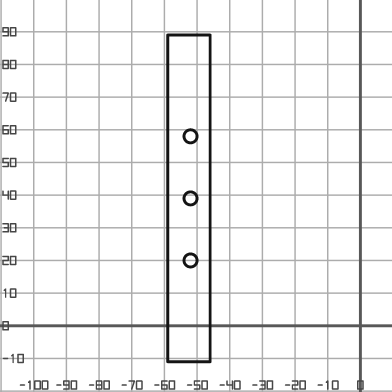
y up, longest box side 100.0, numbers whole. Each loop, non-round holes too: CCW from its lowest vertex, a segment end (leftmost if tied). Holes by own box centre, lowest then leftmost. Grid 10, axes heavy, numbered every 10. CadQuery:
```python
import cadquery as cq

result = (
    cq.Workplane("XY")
    .moveTo(-59.0, -11.0)
    .lineTo(-46.0, -11.0)
    .lineTo(-46.0, 89.0)
    .lineTo(-59.0, 89.0)
    .close()
    .moveTo(-52.0, 20.0)
    .circle(2.0)
    .moveTo(-52.0, 39.0)
    .circle(2.0)
    .moveTo(-52.0, 58.0)
    .circle(2.0)
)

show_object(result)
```